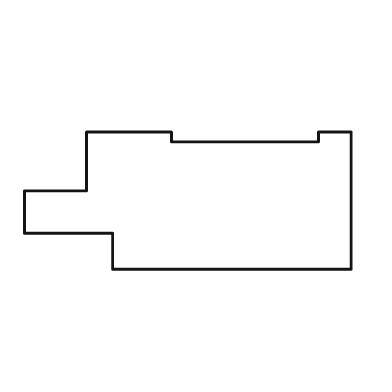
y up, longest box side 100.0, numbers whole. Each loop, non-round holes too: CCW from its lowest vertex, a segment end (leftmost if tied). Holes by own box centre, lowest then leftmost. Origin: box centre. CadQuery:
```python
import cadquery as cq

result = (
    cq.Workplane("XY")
    .moveTo(-23.0, -21.0)
    .lineTo(50.0, -21.0)
    .lineTo(50.0, 21.0)
    .lineTo(40.0, 21.0)
    .lineTo(40.0, 18.0)
    .lineTo(-5.0, 18.0)
    .lineTo(-5.0, 21.0)
    .lineTo(-31.0, 21.0)
    .lineTo(-31.0, 3.0)
    .lineTo(-50.0, 3.0)
    .lineTo(-50.0, -10.0)
    .lineTo(-23.0, -10.0)
    .close()
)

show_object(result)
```